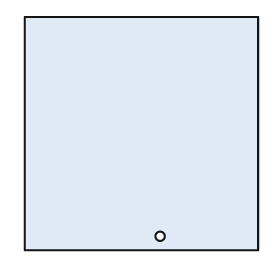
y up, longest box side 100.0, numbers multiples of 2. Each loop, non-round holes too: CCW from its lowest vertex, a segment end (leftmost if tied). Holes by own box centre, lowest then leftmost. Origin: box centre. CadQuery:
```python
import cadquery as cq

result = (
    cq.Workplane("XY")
    .moveTo(-50.0, -50.0)
    .lineTo(50.0, -50.0)
    .lineTo(50.0, 50.0)
    .lineTo(-50.0, 50.0)
    .close()
    .moveTo(8.0, -44.0)
    .circle(2.0)
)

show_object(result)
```